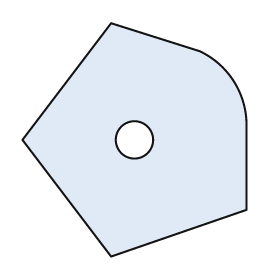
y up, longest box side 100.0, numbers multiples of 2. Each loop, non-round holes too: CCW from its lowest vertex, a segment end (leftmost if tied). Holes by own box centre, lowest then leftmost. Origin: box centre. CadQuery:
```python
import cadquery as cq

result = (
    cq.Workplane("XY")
    .moveTo(-10.0, -50.0)
    .lineTo(48.0, -30.0)
    .lineTo(48.0, 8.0)
    .threePointArc((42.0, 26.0), (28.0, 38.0))
    .lineTo(-10.0, 50.0)
    .lineTo(-48.0, 0.0)
    .close()
    .moveTo(0.0, 0.0)
    .circle(8.0)
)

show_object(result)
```